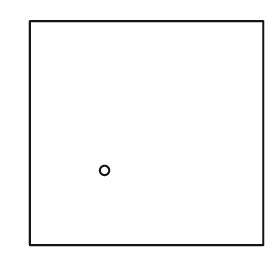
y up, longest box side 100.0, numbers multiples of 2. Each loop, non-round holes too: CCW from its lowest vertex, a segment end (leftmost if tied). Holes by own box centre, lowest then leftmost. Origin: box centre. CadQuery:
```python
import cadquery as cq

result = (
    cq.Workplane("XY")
    .moveTo(-50.0, -48.0)
    .lineTo(50.0, -48.0)
    .lineTo(50.0, 48.0)
    .lineTo(-50.0, 48.0)
    .close()
    .moveTo(-18.0, -16.0)
    .circle(2.0)
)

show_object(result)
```